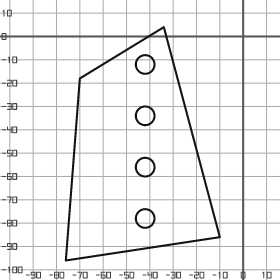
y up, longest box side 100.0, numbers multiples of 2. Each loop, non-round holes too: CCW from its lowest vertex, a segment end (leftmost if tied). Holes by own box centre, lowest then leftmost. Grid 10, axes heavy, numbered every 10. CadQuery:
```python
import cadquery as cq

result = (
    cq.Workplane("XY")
    .moveTo(-76.0, -96.0)
    .lineTo(-10.0, -86.0)
    .lineTo(-34.0, 4.0)
    .lineTo(-70.0, -18.0)
    .close()
    .moveTo(-42.0, -78.0)
    .circle(4.0)
    .moveTo(-42.0, -56.0)
    .circle(4.0)
    .moveTo(-42.0, -34.0)
    .circle(4.0)
    .moveTo(-42.0, -12.0)
    .circle(4.0)
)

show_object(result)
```